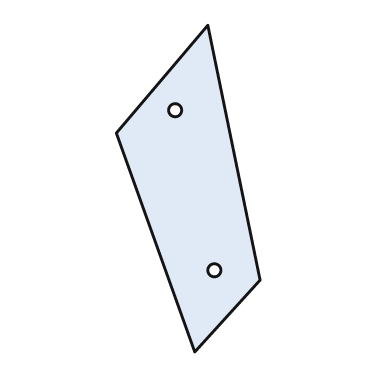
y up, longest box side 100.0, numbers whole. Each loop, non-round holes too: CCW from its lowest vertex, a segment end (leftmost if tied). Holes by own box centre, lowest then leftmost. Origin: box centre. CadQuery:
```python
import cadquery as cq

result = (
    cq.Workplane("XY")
    .moveTo(2.0, -50.0)
    .lineTo(22.0, -28.0)
    .lineTo(6.0, 50.0)
    .lineTo(-22.0, 17.0)
    .close()
    .moveTo(8.0, -25.0)
    .circle(2.0)
    .moveTo(-4.0, 24.0)
    .circle(2.0)
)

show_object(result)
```